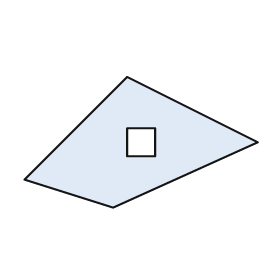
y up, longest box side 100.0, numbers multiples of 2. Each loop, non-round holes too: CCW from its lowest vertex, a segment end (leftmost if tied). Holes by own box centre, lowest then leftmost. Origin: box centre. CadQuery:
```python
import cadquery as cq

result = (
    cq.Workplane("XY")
    .moveTo(-12.0, -28.0)
    .lineTo(50.0, 0.0)
    .lineTo(-6.0, 28.0)
    .lineTo(-50.0, -16.0)
    .close()
    .moveTo(-6.0, -6.0)
    .lineTo(6.0, -6.0)
    .lineTo(6.0, 6.0)
    .lineTo(-6.0, 6.0)
    .close()
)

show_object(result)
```